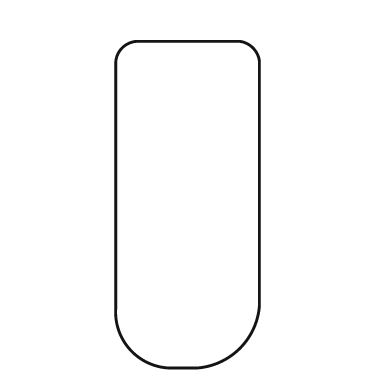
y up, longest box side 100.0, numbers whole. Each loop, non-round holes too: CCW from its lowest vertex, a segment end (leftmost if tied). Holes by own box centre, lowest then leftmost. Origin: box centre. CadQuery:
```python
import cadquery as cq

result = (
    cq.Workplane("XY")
    .moveTo(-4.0, -50.0)
    .lineTo(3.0, -50.0)
    .threePointArc((16.0, -44.0), (22.0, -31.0))
    .lineTo(22.0, 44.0)
    .threePointArc((20.0, 48.0), (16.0, 50.0))
    .lineTo(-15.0, 50.0)
    .threePointArc((-20.0, 48.0), (-22.0, 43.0))
    .lineTo(-22.0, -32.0)
    .threePointArc((-17.0, -45.0), (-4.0, -50.0))
    .close()
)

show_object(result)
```